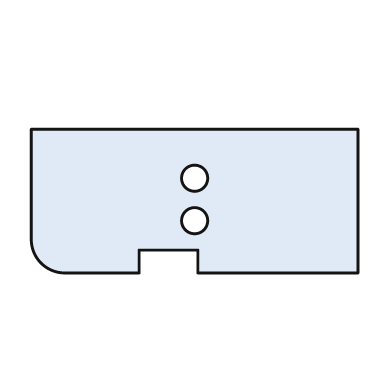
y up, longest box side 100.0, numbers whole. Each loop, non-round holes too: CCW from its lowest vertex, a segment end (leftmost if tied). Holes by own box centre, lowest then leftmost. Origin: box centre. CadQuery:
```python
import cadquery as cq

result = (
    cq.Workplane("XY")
    .moveTo(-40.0, -22.0)
    .lineTo(-17.0, -22.0)
    .lineTo(-17.0, -15.0)
    .lineTo(1.0, -15.0)
    .lineTo(1.0, -22.0)
    .lineTo(50.0, -22.0)
    .lineTo(50.0, 22.0)
    .lineTo(-50.0, 22.0)
    .lineTo(-50.0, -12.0)
    .threePointArc((-47.0, -19.0), (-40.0, -22.0))
    .close()
    .moveTo(0.0, -6.0)
    .circle(4.0)
    .moveTo(0.0, 7.0)
    .circle(4.0)
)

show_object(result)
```